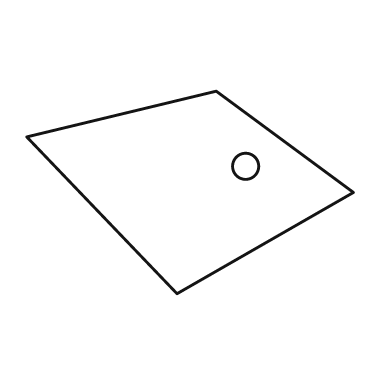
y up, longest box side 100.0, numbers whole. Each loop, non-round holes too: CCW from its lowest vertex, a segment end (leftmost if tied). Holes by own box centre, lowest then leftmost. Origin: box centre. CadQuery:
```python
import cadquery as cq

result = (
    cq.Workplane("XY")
    .moveTo(-4.0, -31.0)
    .lineTo(50.0, 0.0)
    .lineTo(8.0, 31.0)
    .lineTo(-50.0, 17.0)
    .close()
    .moveTo(17.0, 8.0)
    .circle(4.0)
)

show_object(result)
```